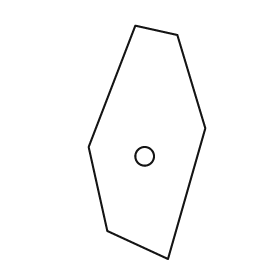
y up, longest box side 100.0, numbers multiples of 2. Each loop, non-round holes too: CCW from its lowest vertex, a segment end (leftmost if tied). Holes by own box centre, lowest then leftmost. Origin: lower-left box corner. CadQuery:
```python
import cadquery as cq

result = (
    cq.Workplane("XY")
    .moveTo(34.0, 0.0)
    .lineTo(50.0, 56.0)
    .lineTo(38.0, 96.0)
    .lineTo(20.0, 100.0)
    .lineTo(0.0, 48.0)
    .lineTo(8.0, 12.0)
    .close()
    .moveTo(24.0, 44.0)
    .circle(4.0)
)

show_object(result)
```